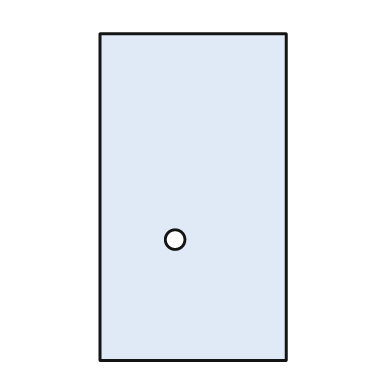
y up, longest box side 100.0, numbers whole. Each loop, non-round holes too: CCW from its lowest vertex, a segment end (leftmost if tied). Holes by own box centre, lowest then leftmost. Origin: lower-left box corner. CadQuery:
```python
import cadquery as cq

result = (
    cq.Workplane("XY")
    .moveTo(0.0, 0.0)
    .lineTo(57.0, 0.0)
    .lineTo(57.0, 100.0)
    .lineTo(0.0, 100.0)
    .close()
    .moveTo(23.0, 37.0)
    .circle(3.0)
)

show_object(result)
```